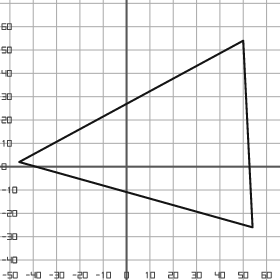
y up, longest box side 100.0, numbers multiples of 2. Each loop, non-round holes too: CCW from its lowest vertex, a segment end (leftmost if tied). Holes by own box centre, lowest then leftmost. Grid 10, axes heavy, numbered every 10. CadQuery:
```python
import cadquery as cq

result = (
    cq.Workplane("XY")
    .moveTo(54.0, -26.0)
    .lineTo(50.0, 54.0)
    .lineTo(-46.0, 2.0)
    .close()
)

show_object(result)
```